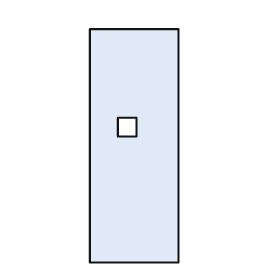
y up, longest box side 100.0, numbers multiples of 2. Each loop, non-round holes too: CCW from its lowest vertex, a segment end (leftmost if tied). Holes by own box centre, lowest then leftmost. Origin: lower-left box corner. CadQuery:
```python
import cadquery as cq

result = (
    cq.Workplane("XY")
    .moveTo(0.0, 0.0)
    .lineTo(38.0, 0.0)
    .lineTo(38.0, 100.0)
    .lineTo(0.0, 100.0)
    .close()
    .moveTo(12.0, 54.0)
    .lineTo(20.0, 54.0)
    .lineTo(20.0, 62.0)
    .lineTo(12.0, 62.0)
    .close()
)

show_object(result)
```